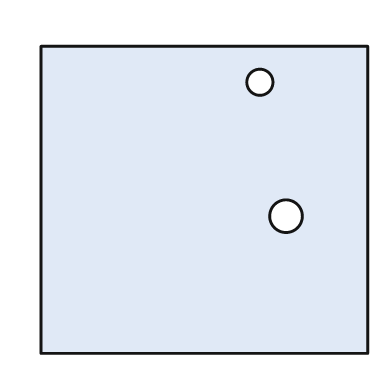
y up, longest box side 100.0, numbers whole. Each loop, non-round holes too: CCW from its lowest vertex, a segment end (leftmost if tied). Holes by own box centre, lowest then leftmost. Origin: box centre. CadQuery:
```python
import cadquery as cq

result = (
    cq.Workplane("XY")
    .moveTo(-50.0, -47.0)
    .lineTo(50.0, -47.0)
    .lineTo(50.0, 47.0)
    .lineTo(-50.0, 47.0)
    .close()
    .moveTo(25.0, -5.0)
    .circle(5.0)
    .moveTo(17.0, 36.0)
    .circle(4.0)
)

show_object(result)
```